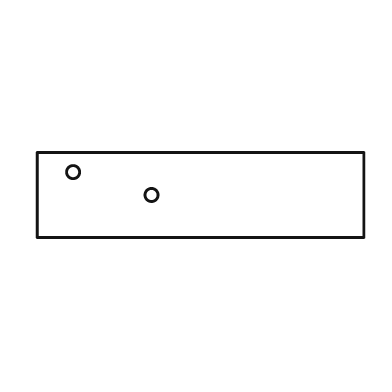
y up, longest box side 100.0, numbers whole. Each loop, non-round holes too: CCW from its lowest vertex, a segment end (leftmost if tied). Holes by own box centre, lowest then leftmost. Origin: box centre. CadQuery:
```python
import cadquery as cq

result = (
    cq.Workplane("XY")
    .moveTo(-50.0, -13.0)
    .lineTo(50.0, -13.0)
    .lineTo(50.0, 13.0)
    .lineTo(-50.0, 13.0)
    .close()
    .moveTo(-15.0, 0.0)
    .circle(2.0)
    .moveTo(-39.0, 7.0)
    .circle(2.0)
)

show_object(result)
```